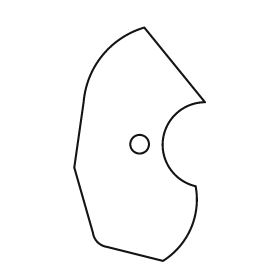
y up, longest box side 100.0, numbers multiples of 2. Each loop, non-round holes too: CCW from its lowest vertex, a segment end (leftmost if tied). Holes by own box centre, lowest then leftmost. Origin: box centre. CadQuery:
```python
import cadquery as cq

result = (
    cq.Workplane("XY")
    .moveTo(10.0, -50.0)
    .threePointArc((22.0, -36.0), (24.0, -18.0))
    .threePointArc((10.0, 2.0), (28.0, 18.0))
    .lineTo(2.0, 50.0)
    .threePointArc((-16.0, 38.0), (-24.0, 18.0))
    .lineTo(-28.0, -10.0)
    .lineTo(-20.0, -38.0)
    .threePointArc((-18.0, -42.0), (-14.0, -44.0))
    .close()
    .moveTo(0.0, 0.0)
    .circle(4.0)
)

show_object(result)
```